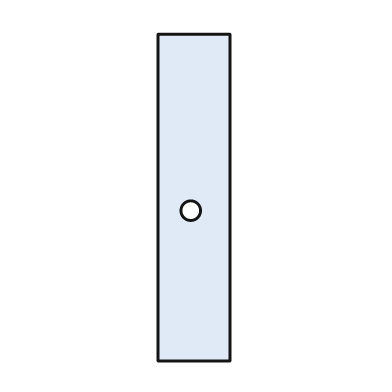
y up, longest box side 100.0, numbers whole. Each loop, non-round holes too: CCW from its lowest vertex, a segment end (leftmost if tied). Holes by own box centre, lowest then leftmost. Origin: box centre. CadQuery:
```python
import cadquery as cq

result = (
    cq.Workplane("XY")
    .moveTo(-11.0, -50.0)
    .lineTo(11.0, -50.0)
    .lineTo(11.0, 50.0)
    .lineTo(-11.0, 50.0)
    .close()
    .moveTo(-1.0, -4.0)
    .circle(3.0)
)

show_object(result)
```